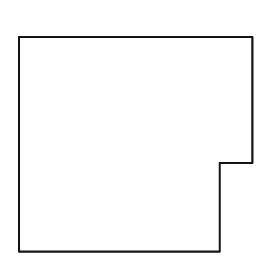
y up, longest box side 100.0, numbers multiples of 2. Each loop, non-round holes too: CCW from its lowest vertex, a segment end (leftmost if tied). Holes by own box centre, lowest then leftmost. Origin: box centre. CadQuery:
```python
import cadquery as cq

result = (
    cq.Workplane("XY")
    .moveTo(-50.0, -46.0)
    .lineTo(36.0, -46.0)
    .lineTo(36.0, -8.0)
    .lineTo(50.0, -8.0)
    .lineTo(50.0, 46.0)
    .lineTo(-50.0, 46.0)
    .close()
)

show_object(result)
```